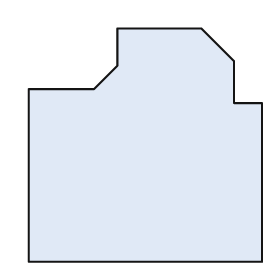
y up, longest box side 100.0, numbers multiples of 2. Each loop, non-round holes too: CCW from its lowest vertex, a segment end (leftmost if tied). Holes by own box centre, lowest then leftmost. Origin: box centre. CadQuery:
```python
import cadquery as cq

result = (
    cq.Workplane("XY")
    .moveTo(-50.0, -50.0)
    .lineTo(50.0, -50.0)
    .lineTo(50.0, 18.0)
    .lineTo(38.0, 18.0)
    .lineTo(38.0, 36.0)
    .lineTo(24.0, 50.0)
    .lineTo(-12.0, 50.0)
    .lineTo(-12.0, 34.0)
    .lineTo(-22.0, 24.0)
    .lineTo(-50.0, 24.0)
    .close()
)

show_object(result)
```